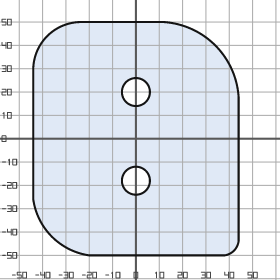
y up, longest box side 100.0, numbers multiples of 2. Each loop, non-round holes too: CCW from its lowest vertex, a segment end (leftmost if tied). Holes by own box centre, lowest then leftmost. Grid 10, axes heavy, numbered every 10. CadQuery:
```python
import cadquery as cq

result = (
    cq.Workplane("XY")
    .moveTo(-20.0, -50.0)
    .lineTo(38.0, -50.0)
    .threePointArc((42.0, -48.0), (44.0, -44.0))
    .lineTo(44.0, 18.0)
    .threePointArc((34.0, 40.0), (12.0, 50.0))
    .lineTo(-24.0, 50.0)
    .threePointArc((-38.0, 44.0), (-44.0, 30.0))
    .lineTo(-44.0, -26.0)
    .threePointArc((-36.0, -42.0), (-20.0, -50.0))
    .close()
    .moveTo(0.0, -18.0)
    .circle(6.0)
    .moveTo(0.0, 20.0)
    .circle(6.0)
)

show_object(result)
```